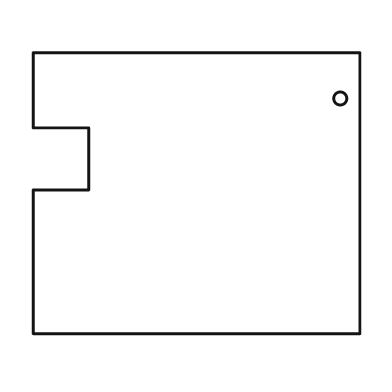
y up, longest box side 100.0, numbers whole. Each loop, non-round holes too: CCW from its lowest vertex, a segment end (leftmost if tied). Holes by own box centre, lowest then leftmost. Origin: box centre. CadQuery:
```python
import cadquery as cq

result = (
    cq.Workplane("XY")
    .moveTo(-50.0, -43.0)
    .lineTo(50.0, -43.0)
    .lineTo(50.0, 43.0)
    .lineTo(-50.0, 43.0)
    .lineTo(-50.0, 20.0)
    .lineTo(-33.0, 20.0)
    .lineTo(-33.0, 1.0)
    .lineTo(-50.0, 1.0)
    .close()
    .moveTo(44.0, 29.0)
    .circle(2.0)
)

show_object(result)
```